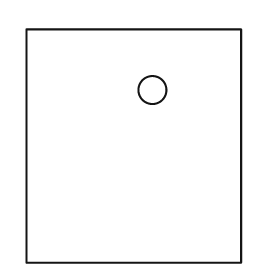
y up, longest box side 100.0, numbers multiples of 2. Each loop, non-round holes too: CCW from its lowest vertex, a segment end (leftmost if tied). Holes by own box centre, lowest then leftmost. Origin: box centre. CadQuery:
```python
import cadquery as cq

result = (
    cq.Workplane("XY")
    .moveTo(-46.0, -50.0)
    .lineTo(46.0, -50.0)
    .lineTo(46.0, 50.0)
    .lineTo(-46.0, 50.0)
    .close()
    .moveTo(8.0, 24.0)
    .circle(6.0)
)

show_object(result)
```